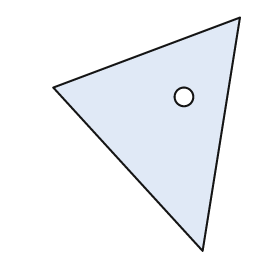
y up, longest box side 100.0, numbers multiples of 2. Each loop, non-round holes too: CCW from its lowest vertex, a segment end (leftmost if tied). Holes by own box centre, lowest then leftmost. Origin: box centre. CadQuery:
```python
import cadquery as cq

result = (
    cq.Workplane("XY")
    .moveTo(24.0, -50.0)
    .lineTo(40.0, 50.0)
    .lineTo(-40.0, 20.0)
    .close()
    .moveTo(16.0, 16.0)
    .circle(4.0)
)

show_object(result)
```